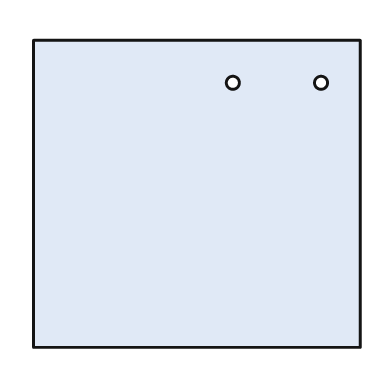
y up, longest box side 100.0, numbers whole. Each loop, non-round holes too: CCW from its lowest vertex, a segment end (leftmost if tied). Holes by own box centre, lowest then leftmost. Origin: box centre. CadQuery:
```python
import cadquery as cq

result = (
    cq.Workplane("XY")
    .moveTo(-50.0, -47.0)
    .lineTo(50.0, -47.0)
    .lineTo(50.0, 47.0)
    .lineTo(-50.0, 47.0)
    .close()
    .moveTo(11.0, 34.0)
    .circle(2.0)
    .moveTo(38.0, 34.0)
    .circle(2.0)
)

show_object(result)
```